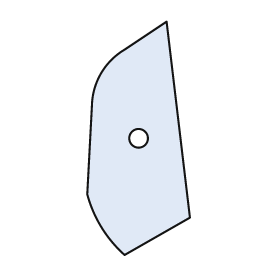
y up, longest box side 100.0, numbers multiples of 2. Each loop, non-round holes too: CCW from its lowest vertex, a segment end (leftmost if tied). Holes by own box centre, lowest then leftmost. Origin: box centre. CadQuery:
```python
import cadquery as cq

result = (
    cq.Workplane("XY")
    .moveTo(-6.0, -50.0)
    .lineTo(22.0, -34.0)
    .lineTo(12.0, 50.0)
    .lineTo(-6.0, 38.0)
    .threePointArc((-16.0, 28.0), (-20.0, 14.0))
    .lineTo(-22.0, -24.0)
    .threePointArc((-16.0, -38.0), (-6.0, -50.0))
    .close()
    .moveTo(0.0, 0.0)
    .circle(4.0)
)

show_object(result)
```